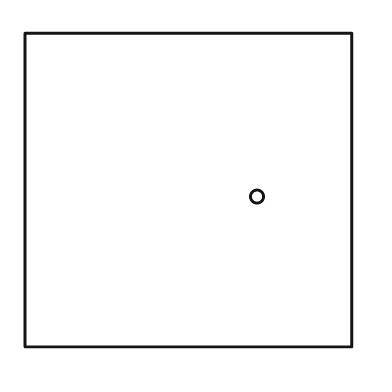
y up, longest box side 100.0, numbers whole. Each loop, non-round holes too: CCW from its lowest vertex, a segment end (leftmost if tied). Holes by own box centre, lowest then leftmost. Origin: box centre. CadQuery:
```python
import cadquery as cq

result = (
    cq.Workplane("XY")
    .moveTo(-50.0, -48.0)
    .lineTo(50.0, -48.0)
    .lineTo(50.0, 48.0)
    .lineTo(-50.0, 48.0)
    .close()
    .moveTo(21.0, -2.0)
    .circle(2.0)
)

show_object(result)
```